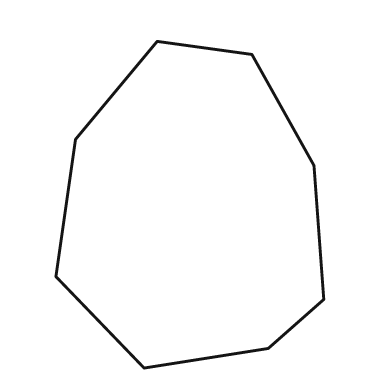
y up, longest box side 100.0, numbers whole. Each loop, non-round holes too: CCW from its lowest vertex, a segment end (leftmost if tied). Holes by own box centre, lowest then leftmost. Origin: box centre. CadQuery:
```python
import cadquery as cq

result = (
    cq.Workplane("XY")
    .moveTo(-14.0, -50.0)
    .lineTo(24.0, -44.0)
    .lineTo(41.0, -29.0)
    .lineTo(38.0, 12.0)
    .lineTo(19.0, 46.0)
    .lineTo(-10.0, 50.0)
    .lineTo(-35.0, 20.0)
    .lineTo(-41.0, -22.0)
    .close()
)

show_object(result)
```